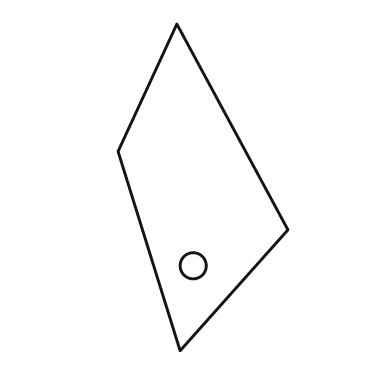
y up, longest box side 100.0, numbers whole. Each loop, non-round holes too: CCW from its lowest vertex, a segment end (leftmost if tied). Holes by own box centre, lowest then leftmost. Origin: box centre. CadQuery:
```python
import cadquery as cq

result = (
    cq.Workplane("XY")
    .moveTo(-7.0, -50.0)
    .lineTo(26.0, -13.0)
    .lineTo(-8.0, 50.0)
    .lineTo(-26.0, 11.0)
    .close()
    .moveTo(-3.0, -24.0)
    .circle(4.0)
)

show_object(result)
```